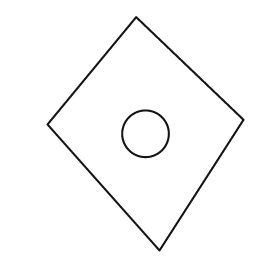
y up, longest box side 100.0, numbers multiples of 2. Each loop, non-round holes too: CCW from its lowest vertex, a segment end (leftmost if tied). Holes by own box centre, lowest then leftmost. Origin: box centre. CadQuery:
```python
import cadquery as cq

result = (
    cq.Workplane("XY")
    .moveTo(6.0, -50.0)
    .lineTo(42.0, 6.0)
    .lineTo(-4.0, 50.0)
    .lineTo(-42.0, 4.0)
    .close()
    .moveTo(0.0, 0.0)
    .circle(10.0)
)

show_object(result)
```